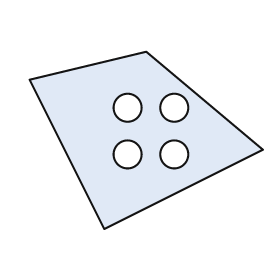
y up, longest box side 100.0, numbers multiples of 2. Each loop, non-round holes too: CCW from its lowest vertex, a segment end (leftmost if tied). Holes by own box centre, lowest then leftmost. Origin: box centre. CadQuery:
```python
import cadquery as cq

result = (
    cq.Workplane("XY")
    .moveTo(-18.0, -38.0)
    .lineTo(50.0, -4.0)
    .lineTo(0.0, 38.0)
    .lineTo(-50.0, 26.0)
    .close()
    .moveTo(-8.0, -6.0)
    .circle(6.0)
    .moveTo(12.0, -6.0)
    .circle(6.0)
    .moveTo(-8.0, 14.0)
    .circle(6.0)
    .moveTo(12.0, 14.0)
    .circle(6.0)
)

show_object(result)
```